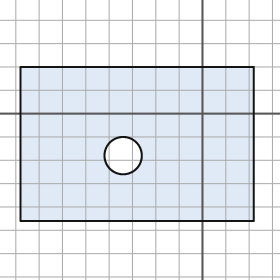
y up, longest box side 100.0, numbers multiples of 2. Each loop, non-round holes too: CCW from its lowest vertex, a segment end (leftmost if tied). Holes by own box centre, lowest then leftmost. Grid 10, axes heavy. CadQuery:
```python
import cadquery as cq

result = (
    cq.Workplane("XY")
    .moveTo(-78.0, -46.0)
    .lineTo(22.0, -46.0)
    .lineTo(22.0, 20.0)
    .lineTo(-78.0, 20.0)
    .close()
    .moveTo(-34.0, -18.0)
    .circle(8.0)
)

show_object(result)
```